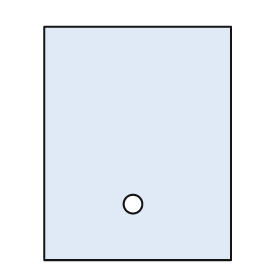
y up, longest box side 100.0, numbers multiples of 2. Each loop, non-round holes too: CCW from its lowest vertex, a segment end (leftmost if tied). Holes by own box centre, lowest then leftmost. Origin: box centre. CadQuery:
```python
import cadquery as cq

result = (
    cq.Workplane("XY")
    .moveTo(-40.0, -50.0)
    .lineTo(40.0, -50.0)
    .lineTo(40.0, 50.0)
    .lineTo(-40.0, 50.0)
    .close()
    .moveTo(-2.0, -26.0)
    .circle(4.0)
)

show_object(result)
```